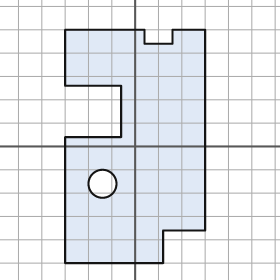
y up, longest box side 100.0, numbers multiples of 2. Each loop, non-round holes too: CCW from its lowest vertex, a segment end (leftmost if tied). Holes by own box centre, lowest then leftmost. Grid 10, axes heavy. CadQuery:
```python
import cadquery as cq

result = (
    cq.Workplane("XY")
    .moveTo(-30.0, -50.0)
    .lineTo(12.0, -50.0)
    .lineTo(12.0, -36.0)
    .lineTo(30.0, -36.0)
    .lineTo(30.0, 50.0)
    .lineTo(16.0, 50.0)
    .lineTo(16.0, 44.0)
    .lineTo(4.0, 44.0)
    .lineTo(4.0, 50.0)
    .lineTo(-30.0, 50.0)
    .lineTo(-30.0, 26.0)
    .lineTo(-6.0, 26.0)
    .lineTo(-6.0, 4.0)
    .lineTo(-30.0, 4.0)
    .close()
    .moveTo(-14.0, -16.0)
    .circle(6.0)
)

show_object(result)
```